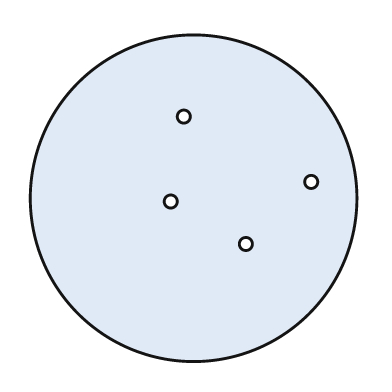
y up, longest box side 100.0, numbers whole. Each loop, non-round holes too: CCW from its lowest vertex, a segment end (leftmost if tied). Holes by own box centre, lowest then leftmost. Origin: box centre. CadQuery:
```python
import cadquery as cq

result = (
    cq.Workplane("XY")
    .moveTo(0.0, 0.0)
    .circle(50.0)
    .moveTo(16.0, -14.0)
    .circle(2.0)
    .moveTo(-7.0, -1.0)
    .circle(2.0)
    .moveTo(36.0, 5.0)
    .circle(2.0)
    .moveTo(-3.0, 25.0)
    .circle(2.0)
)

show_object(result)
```